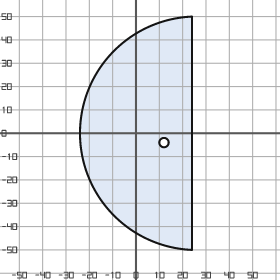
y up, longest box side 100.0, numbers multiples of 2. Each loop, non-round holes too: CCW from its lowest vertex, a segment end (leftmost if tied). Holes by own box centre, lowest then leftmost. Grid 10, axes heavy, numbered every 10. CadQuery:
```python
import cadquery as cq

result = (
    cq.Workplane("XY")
    .moveTo(24.0, -50.0)
    .lineTo(24.0, 50.0)
    .threePointArc((-24.0, 0.0), (24.0, -50.0))
    .close()
    .moveTo(12.0, -4.0)
    .circle(2.0)
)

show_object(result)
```